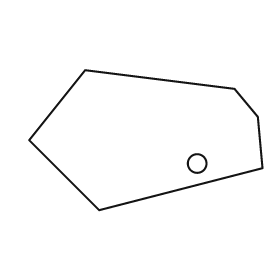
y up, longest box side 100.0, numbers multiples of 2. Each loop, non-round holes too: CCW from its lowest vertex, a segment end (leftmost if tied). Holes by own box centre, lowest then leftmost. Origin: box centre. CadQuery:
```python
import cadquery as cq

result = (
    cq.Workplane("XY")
    .moveTo(-20.0, -30.0)
    .lineTo(50.0, -12.0)
    .lineTo(48.0, 10.0)
    .lineTo(38.0, 22.0)
    .lineTo(-26.0, 30.0)
    .lineTo(-50.0, 0.0)
    .close()
    .moveTo(22.0, -10.0)
    .circle(4.0)
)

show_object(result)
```